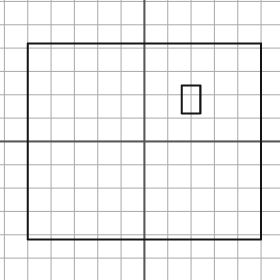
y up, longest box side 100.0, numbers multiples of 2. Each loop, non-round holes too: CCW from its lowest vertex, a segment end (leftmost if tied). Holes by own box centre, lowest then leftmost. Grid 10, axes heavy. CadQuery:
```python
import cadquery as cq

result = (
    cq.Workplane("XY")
    .moveTo(-50.0, -42.0)
    .lineTo(50.0, -42.0)
    .lineTo(50.0, 42.0)
    .lineTo(-50.0, 42.0)
    .close()
    .moveTo(16.0, 12.0)
    .lineTo(24.0, 12.0)
    .lineTo(24.0, 24.0)
    .lineTo(16.0, 24.0)
    .close()
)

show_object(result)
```